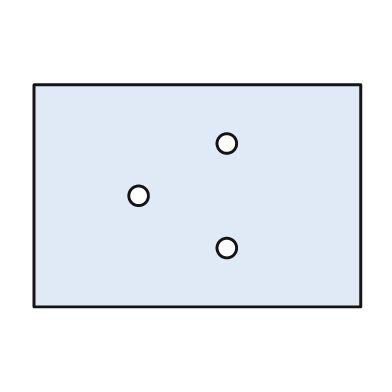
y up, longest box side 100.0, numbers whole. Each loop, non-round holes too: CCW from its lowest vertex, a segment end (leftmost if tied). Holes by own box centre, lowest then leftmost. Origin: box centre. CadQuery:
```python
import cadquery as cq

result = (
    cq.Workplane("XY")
    .moveTo(-50.0, -34.0)
    .lineTo(50.0, -34.0)
    .lineTo(50.0, 34.0)
    .lineTo(-50.0, 34.0)
    .close()
    .moveTo(9.0, -16.0)
    .circle(3.0)
    .moveTo(-18.0, 0.0)
    .circle(3.0)
    .moveTo(9.0, 16.0)
    .circle(3.0)
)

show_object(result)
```